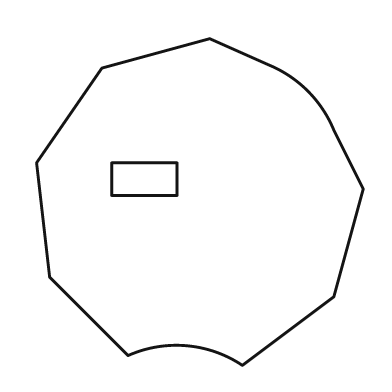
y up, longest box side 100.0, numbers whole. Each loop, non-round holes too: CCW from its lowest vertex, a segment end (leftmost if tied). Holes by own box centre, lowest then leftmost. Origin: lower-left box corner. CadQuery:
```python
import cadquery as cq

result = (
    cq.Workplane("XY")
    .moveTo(63.0, 0.0)
    .lineTo(91.0, 21.0)
    .lineTo(100.0, 54.0)
    .lineTo(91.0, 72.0)
    .threePointArc((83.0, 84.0), (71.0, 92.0))
    .lineTo(53.0, 100.0)
    .lineTo(20.0, 91.0)
    .lineTo(0.0, 62.0)
    .lineTo(4.0, 27.0)
    .lineTo(28.0, 3.0)
    .threePointArc((46.0, 6.0), (63.0, 0.0))
    .close()
    .moveTo(23.0, 52.0)
    .lineTo(43.0, 52.0)
    .lineTo(43.0, 62.0)
    .lineTo(23.0, 62.0)
    .close()
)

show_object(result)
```